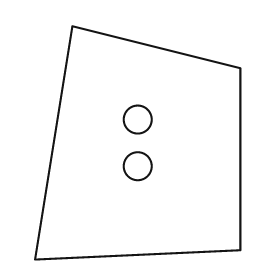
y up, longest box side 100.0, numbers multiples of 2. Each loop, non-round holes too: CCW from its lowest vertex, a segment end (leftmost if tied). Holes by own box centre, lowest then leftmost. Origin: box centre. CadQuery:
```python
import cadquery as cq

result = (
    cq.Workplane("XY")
    .moveTo(-44.0, -50.0)
    .lineTo(44.0, -46.0)
    .lineTo(44.0, 32.0)
    .lineTo(-28.0, 50.0)
    .close()
    .moveTo(0.0, -10.0)
    .circle(6.0)
    .moveTo(0.0, 10.0)
    .circle(6.0)
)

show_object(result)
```